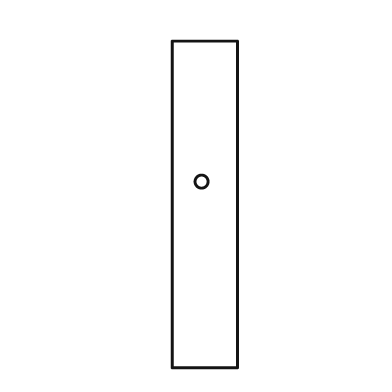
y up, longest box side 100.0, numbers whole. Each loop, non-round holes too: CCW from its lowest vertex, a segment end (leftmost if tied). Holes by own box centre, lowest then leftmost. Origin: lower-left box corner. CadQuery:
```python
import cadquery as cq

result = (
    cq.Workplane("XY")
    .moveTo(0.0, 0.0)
    .lineTo(20.0, 0.0)
    .lineTo(20.0, 100.0)
    .lineTo(0.0, 100.0)
    .close()
    .moveTo(9.0, 57.0)
    .circle(2.0)
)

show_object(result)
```